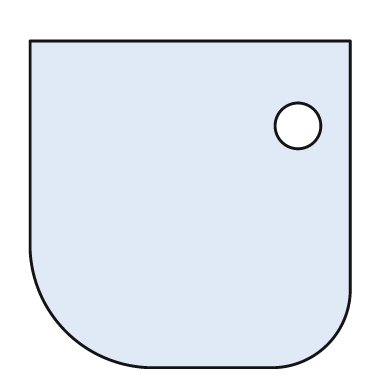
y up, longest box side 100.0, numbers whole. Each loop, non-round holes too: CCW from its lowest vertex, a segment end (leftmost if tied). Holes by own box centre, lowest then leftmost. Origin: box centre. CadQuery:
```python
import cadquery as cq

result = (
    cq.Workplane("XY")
    .moveTo(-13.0, -50.0)
    .lineTo(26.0, -50.0)
    .threePointArc((42.0, -43.0), (49.0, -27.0))
    .lineTo(49.0, 50.0)
    .lineTo(-49.0, 50.0)
    .lineTo(-49.0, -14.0)
    .threePointArc((-38.0, -39.0), (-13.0, -50.0))
    .close()
    .moveTo(33.0, 24.0)
    .circle(7.0)
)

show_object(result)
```